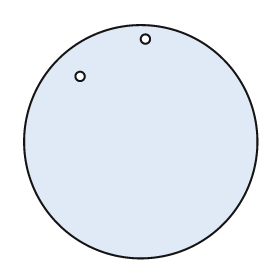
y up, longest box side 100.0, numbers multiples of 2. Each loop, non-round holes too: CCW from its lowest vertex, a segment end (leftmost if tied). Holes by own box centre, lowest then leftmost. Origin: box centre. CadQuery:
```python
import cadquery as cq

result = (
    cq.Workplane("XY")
    .moveTo(0.0, 0.0)
    .circle(50.0)
    .moveTo(-26.0, 28.0)
    .circle(2.0)
    .moveTo(2.0, 44.0)
    .circle(2.0)
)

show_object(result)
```